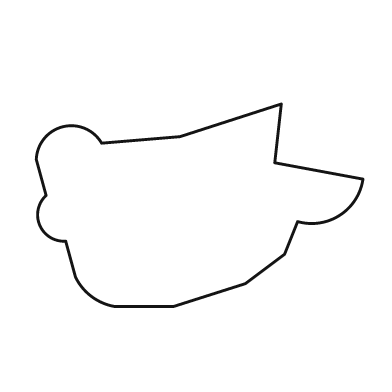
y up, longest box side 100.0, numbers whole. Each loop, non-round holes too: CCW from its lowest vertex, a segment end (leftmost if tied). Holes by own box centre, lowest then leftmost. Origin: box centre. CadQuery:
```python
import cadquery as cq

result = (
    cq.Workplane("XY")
    .moveTo(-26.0, -31.0)
    .lineTo(-8.0, -31.0)
    .lineTo(14.0, -24.0)
    .lineTo(26.0, -15.0)
    .lineTo(30.0, -5.0)
    .threePointArc((43.0, -3.0), (50.0, 8.0))
    .lineTo(23.0, 13.0)
    .lineTo(25.0, 31.0)
    .lineTo(-6.0, 21.0)
    .lineTo(-30.0, 19.0)
    .threePointArc((-42.0, 24.0), (-50.0, 14.0))
    .lineTo(-47.0, 3.0)
    .threePointArc((-49.0, -6.0), (-41.0, -11.0))
    .lineTo(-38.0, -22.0)
    .threePointArc((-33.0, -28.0), (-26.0, -31.0))
    .close()
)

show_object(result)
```